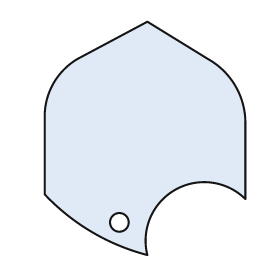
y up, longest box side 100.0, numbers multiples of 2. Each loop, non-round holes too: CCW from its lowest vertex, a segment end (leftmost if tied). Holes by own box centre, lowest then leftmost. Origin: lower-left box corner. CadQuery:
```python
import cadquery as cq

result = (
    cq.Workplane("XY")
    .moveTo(44.0, 0.0)
    .threePointArc((56.0, 28.0), (86.0, 24.0))
    .lineTo(86.0, 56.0)
    .threePointArc((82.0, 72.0), (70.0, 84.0))
    .lineTo(44.0, 100.0)
    .lineTo(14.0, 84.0)
    .threePointArc((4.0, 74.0), (0.0, 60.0))
    .lineTo(0.0, 26.0)
    .threePointArc((20.0, 10.0), (44.0, 0.0))
    .close()
    .moveTo(32.0, 14.0)
    .circle(4.0)
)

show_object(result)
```